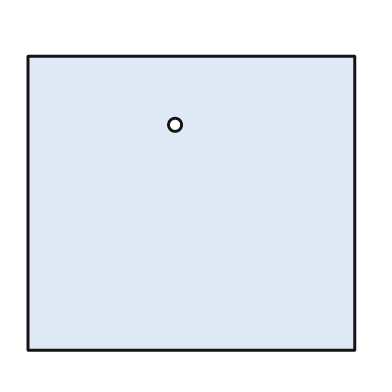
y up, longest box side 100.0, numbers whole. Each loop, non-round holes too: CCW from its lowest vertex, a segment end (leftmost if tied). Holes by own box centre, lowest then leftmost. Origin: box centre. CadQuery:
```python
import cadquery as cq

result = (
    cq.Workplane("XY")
    .moveTo(-50.0, -45.0)
    .lineTo(50.0, -45.0)
    .lineTo(50.0, 45.0)
    .lineTo(-50.0, 45.0)
    .close()
    .moveTo(-5.0, 24.0)
    .circle(2.0)
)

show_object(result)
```